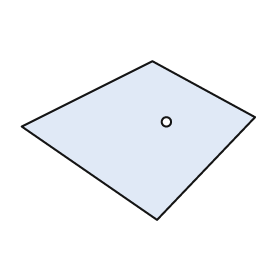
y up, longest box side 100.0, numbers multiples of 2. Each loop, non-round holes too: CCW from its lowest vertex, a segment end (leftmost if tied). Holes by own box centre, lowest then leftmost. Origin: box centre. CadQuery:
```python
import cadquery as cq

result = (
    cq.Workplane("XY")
    .moveTo(8.0, -34.0)
    .lineTo(50.0, 10.0)
    .lineTo(6.0, 34.0)
    .lineTo(-50.0, 6.0)
    .close()
    .moveTo(12.0, 8.0)
    .circle(2.0)
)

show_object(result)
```